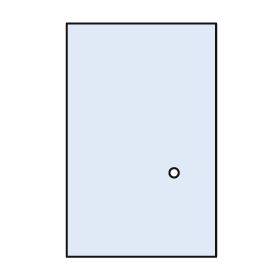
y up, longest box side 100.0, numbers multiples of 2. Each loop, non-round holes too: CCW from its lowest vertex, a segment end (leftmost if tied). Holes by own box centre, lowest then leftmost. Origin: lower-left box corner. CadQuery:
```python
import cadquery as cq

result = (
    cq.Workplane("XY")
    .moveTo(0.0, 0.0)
    .lineTo(64.0, 0.0)
    .lineTo(64.0, 100.0)
    .lineTo(0.0, 100.0)
    .close()
    .moveTo(46.0, 36.0)
    .circle(2.0)
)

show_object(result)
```